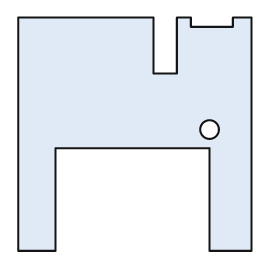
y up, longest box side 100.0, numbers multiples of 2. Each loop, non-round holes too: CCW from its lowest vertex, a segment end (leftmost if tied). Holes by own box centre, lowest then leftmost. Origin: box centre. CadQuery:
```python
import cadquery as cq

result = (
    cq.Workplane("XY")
    .moveTo(-50.0, -50.0)
    .lineTo(-34.0, -50.0)
    .lineTo(-34.0, -6.0)
    .lineTo(32.0, -6.0)
    .lineTo(32.0, -50.0)
    .lineTo(50.0, -50.0)
    .lineTo(50.0, 50.0)
    .lineTo(42.0, 50.0)
    .lineTo(42.0, 46.0)
    .lineTo(24.0, 46.0)
    .lineTo(24.0, 50.0)
    .lineTo(18.0, 50.0)
    .lineTo(18.0, 26.0)
    .lineTo(8.0, 26.0)
    .lineTo(8.0, 50.0)
    .lineTo(-50.0, 50.0)
    .close()
    .moveTo(32.0, 2.0)
    .circle(4.0)
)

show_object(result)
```